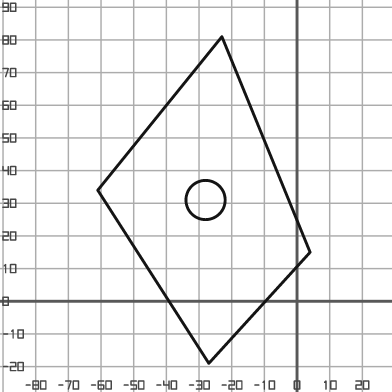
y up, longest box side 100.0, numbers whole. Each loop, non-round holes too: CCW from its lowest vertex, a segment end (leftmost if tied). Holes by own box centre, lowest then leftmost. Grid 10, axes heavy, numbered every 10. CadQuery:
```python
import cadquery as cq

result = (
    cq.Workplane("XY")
    .moveTo(-27.0, -19.0)
    .lineTo(4.0, 15.0)
    .lineTo(-23.0, 81.0)
    .lineTo(-61.0, 34.0)
    .close()
    .moveTo(-28.0, 31.0)
    .circle(6.0)
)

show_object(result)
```